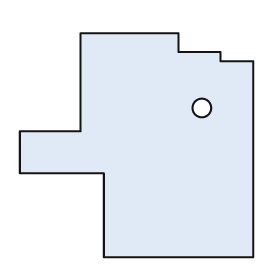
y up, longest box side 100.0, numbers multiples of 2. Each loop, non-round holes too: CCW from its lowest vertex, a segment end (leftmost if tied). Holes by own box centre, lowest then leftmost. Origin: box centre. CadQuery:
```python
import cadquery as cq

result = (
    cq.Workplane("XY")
    .moveTo(-14.0, -48.0)
    .lineTo(50.0, -48.0)
    .lineTo(50.0, 36.0)
    .lineTo(36.0, 36.0)
    .lineTo(36.0, 40.0)
    .lineTo(18.0, 40.0)
    .lineTo(18.0, 48.0)
    .lineTo(-24.0, 48.0)
    .lineTo(-24.0, 6.0)
    .lineTo(-50.0, 6.0)
    .lineTo(-50.0, -12.0)
    .lineTo(-14.0, -12.0)
    .close()
    .moveTo(28.0, 16.0)
    .circle(4.0)
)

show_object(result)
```